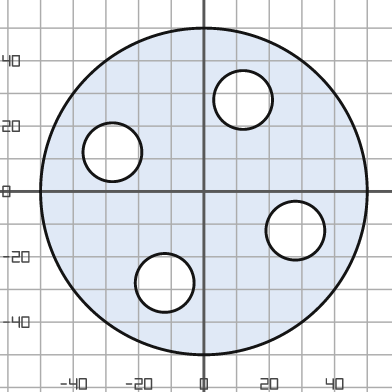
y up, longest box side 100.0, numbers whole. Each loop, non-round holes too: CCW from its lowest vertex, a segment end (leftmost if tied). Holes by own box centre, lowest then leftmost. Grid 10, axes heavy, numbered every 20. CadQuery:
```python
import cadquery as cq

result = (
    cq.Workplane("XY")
    .moveTo(0.0, 0.0)
    .circle(50.0)
    .moveTo(-12.0, -28.0)
    .circle(9.0)
    .moveTo(28.0, -12.0)
    .circle(9.0)
    .moveTo(-28.0, 12.0)
    .circle(9.0)
    .moveTo(12.0, 28.0)
    .circle(9.0)
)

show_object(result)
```